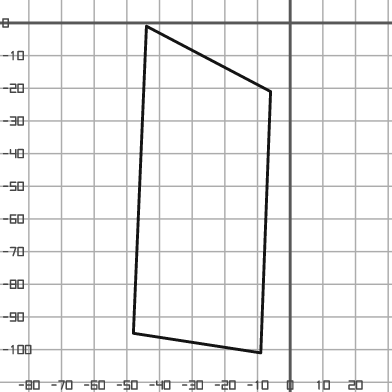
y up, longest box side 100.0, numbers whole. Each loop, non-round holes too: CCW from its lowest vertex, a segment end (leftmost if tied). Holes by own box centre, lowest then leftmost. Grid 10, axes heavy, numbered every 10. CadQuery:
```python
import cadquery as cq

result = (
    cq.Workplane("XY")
    .moveTo(-9.0, -101.0)
    .lineTo(-6.0, -21.0)
    .lineTo(-44.0, -1.0)
    .lineTo(-48.0, -95.0)
    .close()
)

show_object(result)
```